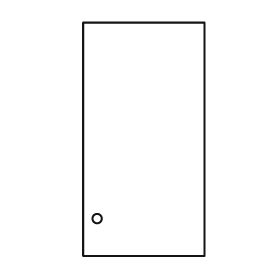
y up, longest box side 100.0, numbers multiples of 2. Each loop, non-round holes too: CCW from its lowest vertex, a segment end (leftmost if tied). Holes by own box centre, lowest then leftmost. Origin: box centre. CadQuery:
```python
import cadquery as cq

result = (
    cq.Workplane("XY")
    .moveTo(-26.0, -50.0)
    .lineTo(26.0, -50.0)
    .lineTo(26.0, 50.0)
    .lineTo(-26.0, 50.0)
    .close()
    .moveTo(-20.0, -34.0)
    .circle(2.0)
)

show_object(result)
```